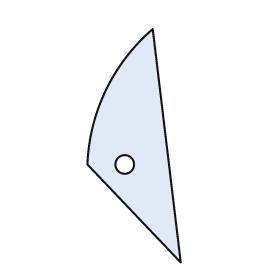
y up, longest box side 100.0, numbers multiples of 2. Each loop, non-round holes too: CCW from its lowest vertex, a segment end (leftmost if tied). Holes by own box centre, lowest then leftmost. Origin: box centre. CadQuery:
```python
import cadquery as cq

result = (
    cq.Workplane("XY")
    .moveTo(20.0, -50.0)
    .lineTo(8.0, 50.0)
    .threePointArc((-12.0, 24.0), (-20.0, -8.0))
    .close()
    .moveTo(-4.0, -8.0)
    .circle(4.0)
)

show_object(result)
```